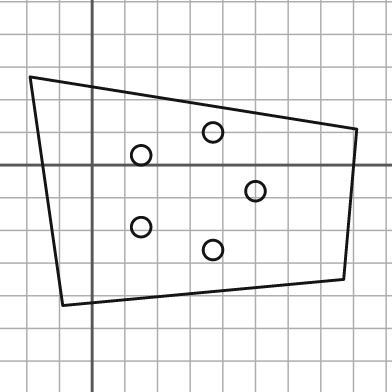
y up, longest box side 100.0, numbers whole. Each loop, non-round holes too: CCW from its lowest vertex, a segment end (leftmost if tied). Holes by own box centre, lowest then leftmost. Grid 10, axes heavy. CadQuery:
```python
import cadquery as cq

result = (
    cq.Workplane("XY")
    .moveTo(-9.0, -43.0)
    .lineTo(77.0, -35.0)
    .lineTo(81.0, 11.0)
    .lineTo(-19.0, 27.0)
    .close()
    .moveTo(37.0, -26.0)
    .circle(3.0)
    .moveTo(15.0, -19.0)
    .circle(3.0)
    .moveTo(50.0, -8.0)
    .circle(3.0)
    .moveTo(15.0, 3.0)
    .circle(3.0)
    .moveTo(37.0, 10.0)
    .circle(3.0)
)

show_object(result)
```